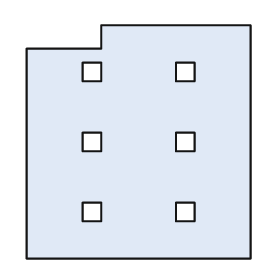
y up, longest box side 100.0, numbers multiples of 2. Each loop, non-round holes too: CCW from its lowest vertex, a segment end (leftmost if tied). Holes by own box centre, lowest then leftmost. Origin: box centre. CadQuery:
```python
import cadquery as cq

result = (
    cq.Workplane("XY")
    .moveTo(-48.0, -50.0)
    .lineTo(48.0, -50.0)
    .lineTo(48.0, 50.0)
    .lineTo(-16.0, 50.0)
    .lineTo(-16.0, 40.0)
    .lineTo(-48.0, 40.0)
    .close()
    .moveTo(-24.0, -34.0)
    .lineTo(-16.0, -34.0)
    .lineTo(-16.0, -26.0)
    .lineTo(-24.0, -26.0)
    .close()
    .moveTo(16.0, -34.0)
    .lineTo(24.0, -34.0)
    .lineTo(24.0, -26.0)
    .lineTo(16.0, -26.0)
    .close()
    .moveTo(-24.0, -4.0)
    .lineTo(-16.0, -4.0)
    .lineTo(-16.0, 4.0)
    .lineTo(-24.0, 4.0)
    .close()
    .moveTo(16.0, -4.0)
    .lineTo(24.0, -4.0)
    .lineTo(24.0, 4.0)
    .lineTo(16.0, 4.0)
    .close()
    .moveTo(-24.0, 26.0)
    .lineTo(-16.0, 26.0)
    .lineTo(-16.0, 34.0)
    .lineTo(-24.0, 34.0)
    .close()
    .moveTo(16.0, 26.0)
    .lineTo(24.0, 26.0)
    .lineTo(24.0, 34.0)
    .lineTo(16.0, 34.0)
    .close()
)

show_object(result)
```